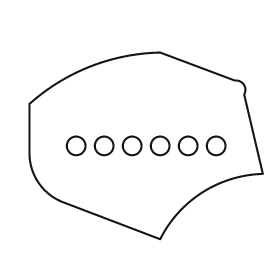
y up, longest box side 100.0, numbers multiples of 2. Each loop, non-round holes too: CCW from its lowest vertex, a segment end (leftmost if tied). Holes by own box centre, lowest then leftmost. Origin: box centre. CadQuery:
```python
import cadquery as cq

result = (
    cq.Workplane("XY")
    .moveTo(6.0, -40.0)
    .threePointArc((24.0, -20.0), (50.0, -12.0))
    .lineTo(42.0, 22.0)
    .threePointArc((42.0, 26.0), (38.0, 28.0))
    .lineTo(6.0, 40.0)
    .threePointArc((-24.0, 34.0), (-50.0, 18.0))
    .lineTo(-50.0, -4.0)
    .threePointArc((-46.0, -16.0), (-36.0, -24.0))
    .close()
    .moveTo(-30.0, 0.0)
    .circle(4.0)
    .moveTo(-18.0, 0.0)
    .circle(4.0)
    .moveTo(-6.0, 0.0)
    .circle(4.0)
    .moveTo(6.0, 0.0)
    .circle(4.0)
    .moveTo(18.0, 0.0)
    .circle(4.0)
    .moveTo(30.0, 0.0)
    .circle(4.0)
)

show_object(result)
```